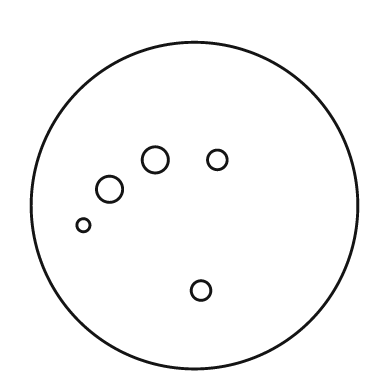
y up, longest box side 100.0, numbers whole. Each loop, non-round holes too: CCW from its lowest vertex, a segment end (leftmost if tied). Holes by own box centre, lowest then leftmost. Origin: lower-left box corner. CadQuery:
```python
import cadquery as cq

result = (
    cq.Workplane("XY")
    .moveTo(50.0, 50.0)
    .circle(50.0)
    .moveTo(52.0, 24.0)
    .circle(3.0)
    .moveTo(16.0, 44.0)
    .circle(2.0)
    .moveTo(24.0, 55.0)
    .circle(4.0)
    .moveTo(38.0, 64.0)
    .circle(4.0)
    .moveTo(57.0, 64.0)
    .circle(3.0)
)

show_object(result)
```